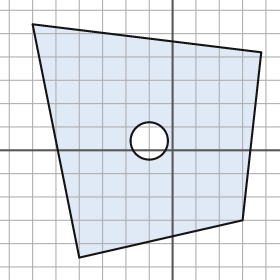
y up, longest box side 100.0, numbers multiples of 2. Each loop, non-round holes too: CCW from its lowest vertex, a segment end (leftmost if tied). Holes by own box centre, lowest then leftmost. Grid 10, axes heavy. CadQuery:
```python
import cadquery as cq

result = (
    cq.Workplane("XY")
    .moveTo(-40.0, -46.0)
    .lineTo(30.0, -30.0)
    .lineTo(38.0, 42.0)
    .lineTo(-60.0, 54.0)
    .close()
    .moveTo(-10.0, 4.0)
    .circle(8.0)
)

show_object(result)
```